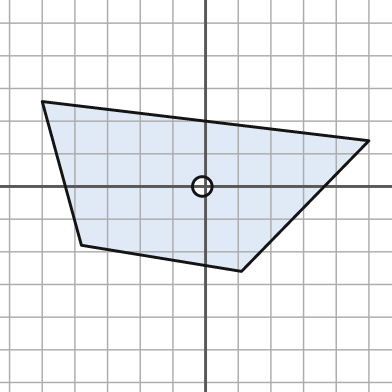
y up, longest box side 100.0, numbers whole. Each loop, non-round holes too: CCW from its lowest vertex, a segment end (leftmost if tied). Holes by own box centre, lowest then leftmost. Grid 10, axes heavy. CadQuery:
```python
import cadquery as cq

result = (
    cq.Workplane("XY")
    .moveTo(11.0, -26.0)
    .lineTo(50.0, 14.0)
    .lineTo(-50.0, 26.0)
    .lineTo(-38.0, -18.0)
    .close()
    .moveTo(-1.0, 0.0)
    .circle(3.0)
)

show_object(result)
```